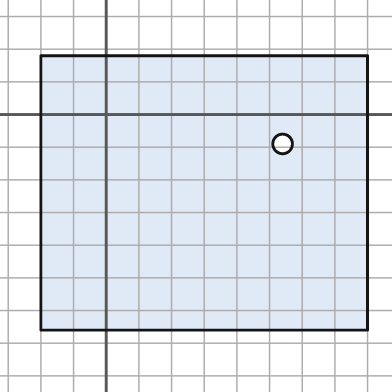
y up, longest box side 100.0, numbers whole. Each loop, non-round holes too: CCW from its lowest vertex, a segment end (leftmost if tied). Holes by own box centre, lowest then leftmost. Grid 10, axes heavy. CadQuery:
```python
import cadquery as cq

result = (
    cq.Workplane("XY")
    .moveTo(-20.0, -66.0)
    .lineTo(80.0, -66.0)
    .lineTo(80.0, 18.0)
    .lineTo(-20.0, 18.0)
    .close()
    .moveTo(54.0, -9.0)
    .circle(3.0)
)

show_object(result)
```